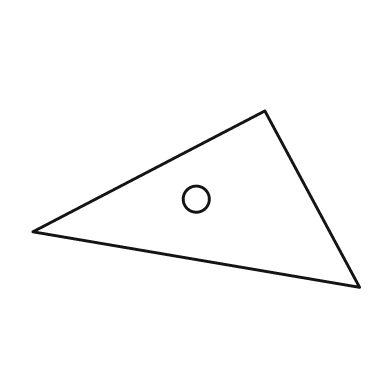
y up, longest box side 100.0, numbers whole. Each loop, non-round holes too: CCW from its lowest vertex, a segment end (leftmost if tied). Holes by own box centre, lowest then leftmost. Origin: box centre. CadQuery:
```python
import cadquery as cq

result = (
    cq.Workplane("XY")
    .moveTo(50.0, -27.0)
    .lineTo(21.0, 27.0)
    .lineTo(-50.0, -10.0)
    .close()
    .moveTo(0.0, 0.0)
    .circle(4.0)
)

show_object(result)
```